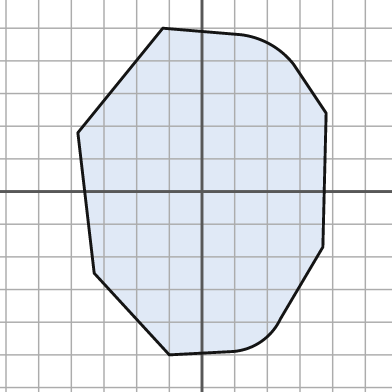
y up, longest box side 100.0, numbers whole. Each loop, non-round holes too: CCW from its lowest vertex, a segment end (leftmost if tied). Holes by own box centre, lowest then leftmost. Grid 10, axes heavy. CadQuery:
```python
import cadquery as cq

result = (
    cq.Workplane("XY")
    .moveTo(-10.0, -50.0)
    .lineTo(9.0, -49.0)
    .threePointArc((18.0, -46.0), (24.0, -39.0))
    .lineTo(37.0, -17.0)
    .lineTo(38.0, 24.0)
    .lineTo(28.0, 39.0)
    .threePointArc((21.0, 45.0), (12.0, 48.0))
    .lineTo(-12.0, 50.0)
    .lineTo(-38.0, 18.0)
    .lineTo(-33.0, -25.0)
    .close()
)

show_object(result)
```